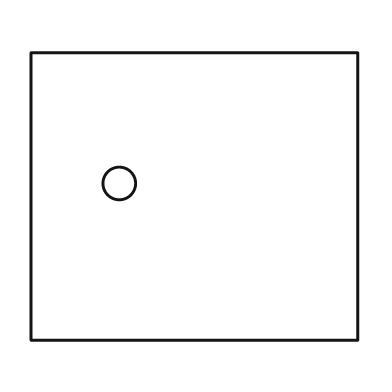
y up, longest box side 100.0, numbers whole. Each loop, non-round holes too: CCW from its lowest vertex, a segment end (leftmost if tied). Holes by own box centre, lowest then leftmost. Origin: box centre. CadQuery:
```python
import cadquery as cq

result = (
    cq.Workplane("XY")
    .moveTo(-50.0, -44.0)
    .lineTo(50.0, -44.0)
    .lineTo(50.0, 44.0)
    .lineTo(-50.0, 44.0)
    .close()
    .moveTo(-23.0, 4.0)
    .circle(5.0)
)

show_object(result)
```